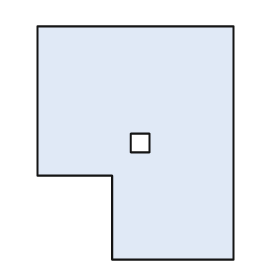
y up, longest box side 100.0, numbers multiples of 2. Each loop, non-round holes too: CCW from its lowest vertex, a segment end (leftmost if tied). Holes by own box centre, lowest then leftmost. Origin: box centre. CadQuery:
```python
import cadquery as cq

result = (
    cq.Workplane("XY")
    .moveTo(-10.0, -50.0)
    .lineTo(42.0, -50.0)
    .lineTo(42.0, 50.0)
    .lineTo(-42.0, 50.0)
    .lineTo(-42.0, -14.0)
    .lineTo(-10.0, -14.0)
    .close()
    .moveTo(-2.0, -4.0)
    .lineTo(6.0, -4.0)
    .lineTo(6.0, 4.0)
    .lineTo(-2.0, 4.0)
    .close()
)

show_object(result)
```